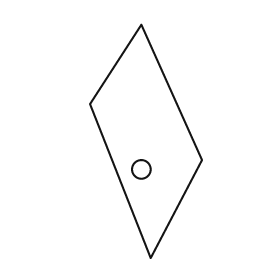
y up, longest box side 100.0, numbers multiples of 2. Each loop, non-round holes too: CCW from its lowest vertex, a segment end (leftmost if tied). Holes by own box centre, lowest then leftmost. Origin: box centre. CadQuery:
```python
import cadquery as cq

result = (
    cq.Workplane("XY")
    .moveTo(2.0, -50.0)
    .lineTo(24.0, -8.0)
    .lineTo(-2.0, 50.0)
    .lineTo(-24.0, 16.0)
    .close()
    .moveTo(-2.0, -12.0)
    .circle(4.0)
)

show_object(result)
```